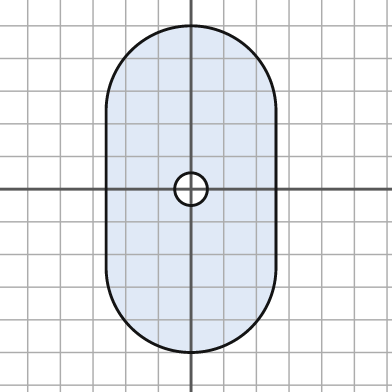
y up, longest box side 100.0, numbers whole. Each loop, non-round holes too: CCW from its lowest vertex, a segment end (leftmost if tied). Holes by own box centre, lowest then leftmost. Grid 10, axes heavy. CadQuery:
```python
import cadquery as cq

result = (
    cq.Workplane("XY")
    .moveTo(-26.0, -24.0)
    .threePointArc((0.0, -50.0), (26.0, -24.0))
    .lineTo(26.0, 24.0)
    .threePointArc((0.0, 50.0), (-26.0, 24.0))
    .close()
    .moveTo(0.0, 0.0)
    .circle(5.0)
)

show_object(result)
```